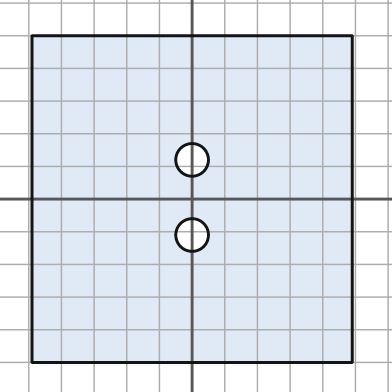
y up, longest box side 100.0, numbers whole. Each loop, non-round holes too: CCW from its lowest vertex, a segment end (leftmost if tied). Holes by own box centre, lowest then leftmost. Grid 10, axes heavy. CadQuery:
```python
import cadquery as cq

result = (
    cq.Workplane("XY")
    .moveTo(-49.0, -50.0)
    .lineTo(49.0, -50.0)
    .lineTo(49.0, 50.0)
    .lineTo(-49.0, 50.0)
    .close()
    .moveTo(0.0, -11.0)
    .circle(5.0)
    .moveTo(0.0, 12.0)
    .circle(5.0)
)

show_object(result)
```